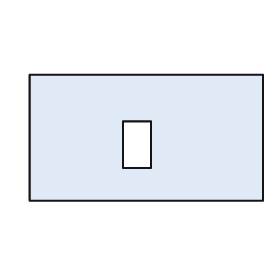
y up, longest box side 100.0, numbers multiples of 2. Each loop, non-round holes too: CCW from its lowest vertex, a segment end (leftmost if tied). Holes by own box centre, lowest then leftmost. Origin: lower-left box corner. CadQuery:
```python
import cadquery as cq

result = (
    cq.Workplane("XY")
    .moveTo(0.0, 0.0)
    .lineTo(100.0, 0.0)
    .lineTo(100.0, 54.0)
    .lineTo(0.0, 54.0)
    .close()
    .moveTo(40.0, 14.0)
    .lineTo(52.0, 14.0)
    .lineTo(52.0, 34.0)
    .lineTo(40.0, 34.0)
    .close()
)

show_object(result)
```